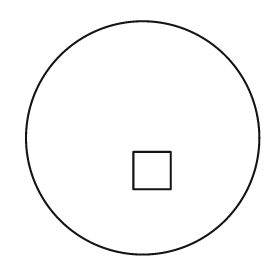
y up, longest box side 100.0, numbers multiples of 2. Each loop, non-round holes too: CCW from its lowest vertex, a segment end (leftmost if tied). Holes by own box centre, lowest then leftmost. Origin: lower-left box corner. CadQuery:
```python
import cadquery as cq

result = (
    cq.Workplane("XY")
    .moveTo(50.0, 50.0)
    .circle(50.0)
    .moveTo(46.0, 28.0)
    .lineTo(62.0, 28.0)
    .lineTo(62.0, 44.0)
    .lineTo(46.0, 44.0)
    .close()
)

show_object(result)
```